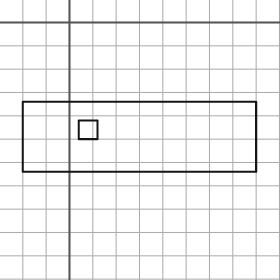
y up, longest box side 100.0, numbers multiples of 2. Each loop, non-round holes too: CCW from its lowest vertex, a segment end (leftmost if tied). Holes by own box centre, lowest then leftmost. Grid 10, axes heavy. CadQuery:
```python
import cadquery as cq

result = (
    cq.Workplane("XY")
    .moveTo(-20.0, -64.0)
    .lineTo(80.0, -64.0)
    .lineTo(80.0, -34.0)
    .lineTo(-20.0, -34.0)
    .close()
    .moveTo(4.0, -50.0)
    .lineTo(12.0, -50.0)
    .lineTo(12.0, -42.0)
    .lineTo(4.0, -42.0)
    .close()
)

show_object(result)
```